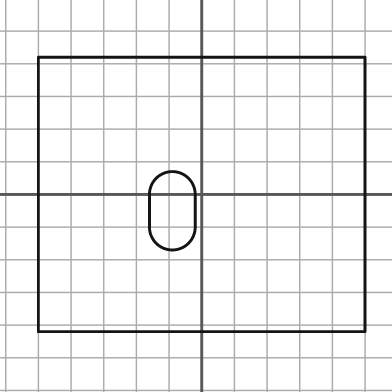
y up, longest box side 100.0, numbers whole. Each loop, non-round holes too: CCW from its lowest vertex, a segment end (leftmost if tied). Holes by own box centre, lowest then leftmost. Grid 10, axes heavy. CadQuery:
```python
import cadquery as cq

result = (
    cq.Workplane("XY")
    .moveTo(-50.0, -42.0)
    .lineTo(50.0, -42.0)
    .lineTo(50.0, 42.0)
    .lineTo(-50.0, 42.0)
    .close()
    .moveTo(-16.0, -10.0)
    .threePointArc((-9.0, -17.0), (-2.0, -10.0))
    .lineTo(-2.0, 0.0)
    .threePointArc((-9.0, 7.0), (-16.0, 0.0))
    .close()
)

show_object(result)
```